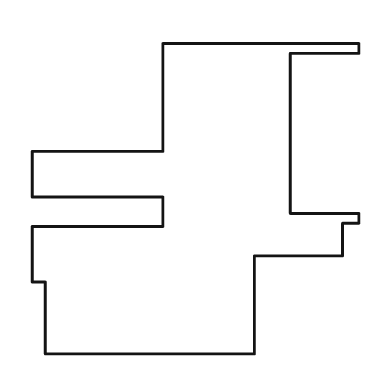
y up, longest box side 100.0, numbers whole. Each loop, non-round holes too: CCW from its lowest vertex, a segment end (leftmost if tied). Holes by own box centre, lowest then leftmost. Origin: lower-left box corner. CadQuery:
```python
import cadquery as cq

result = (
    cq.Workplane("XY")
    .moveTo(4.0, 0.0)
    .lineTo(68.0, 0.0)
    .lineTo(68.0, 30.0)
    .lineTo(95.0, 30.0)
    .lineTo(95.0, 40.0)
    .lineTo(100.0, 40.0)
    .lineTo(100.0, 43.0)
    .lineTo(79.0, 43.0)
    .lineTo(79.0, 92.0)
    .lineTo(100.0, 92.0)
    .lineTo(100.0, 95.0)
    .lineTo(40.0, 95.0)
    .lineTo(40.0, 62.0)
    .lineTo(0.0, 62.0)
    .lineTo(0.0, 48.0)
    .lineTo(40.0, 48.0)
    .lineTo(40.0, 39.0)
    .lineTo(0.0, 39.0)
    .lineTo(0.0, 22.0)
    .lineTo(4.0, 22.0)
    .close()
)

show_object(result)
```